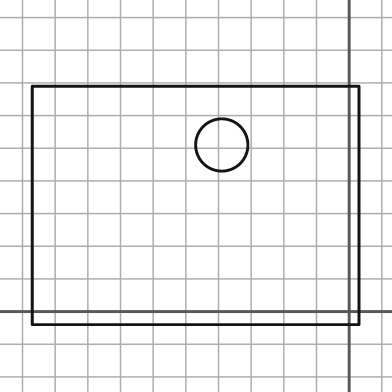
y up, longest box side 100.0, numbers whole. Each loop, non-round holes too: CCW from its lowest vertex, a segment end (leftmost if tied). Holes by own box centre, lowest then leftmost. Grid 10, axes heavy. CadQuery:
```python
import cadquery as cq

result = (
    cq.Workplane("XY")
    .moveTo(-97.0, -4.0)
    .lineTo(3.0, -4.0)
    .lineTo(3.0, 69.0)
    .lineTo(-97.0, 69.0)
    .close()
    .moveTo(-39.0, 51.0)
    .circle(8.0)
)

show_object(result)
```